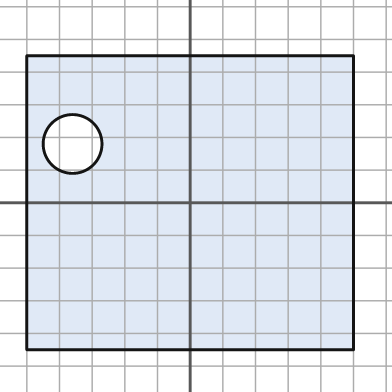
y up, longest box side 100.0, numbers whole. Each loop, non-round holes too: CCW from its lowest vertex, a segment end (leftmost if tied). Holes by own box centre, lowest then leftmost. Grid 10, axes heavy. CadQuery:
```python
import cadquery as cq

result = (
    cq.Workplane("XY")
    .moveTo(-50.0, -45.0)
    .lineTo(50.0, -45.0)
    .lineTo(50.0, 45.0)
    .lineTo(-50.0, 45.0)
    .close()
    .moveTo(-36.0, 18.0)
    .circle(9.0)
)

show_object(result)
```